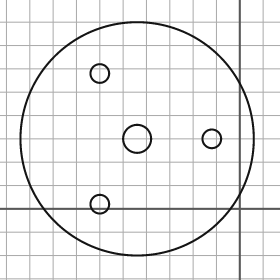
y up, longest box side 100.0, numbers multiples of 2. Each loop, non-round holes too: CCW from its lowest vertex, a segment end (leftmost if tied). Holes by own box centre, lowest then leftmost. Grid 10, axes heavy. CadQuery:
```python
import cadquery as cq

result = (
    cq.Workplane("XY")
    .moveTo(-44.0, 30.0)
    .circle(50.0)
    .moveTo(-60.0, 2.0)
    .circle(4.0)
    .moveTo(-44.0, 30.0)
    .circle(6.0)
    .moveTo(-12.0, 30.0)
    .circle(4.0)
    .moveTo(-60.0, 58.0)
    .circle(4.0)
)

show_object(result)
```